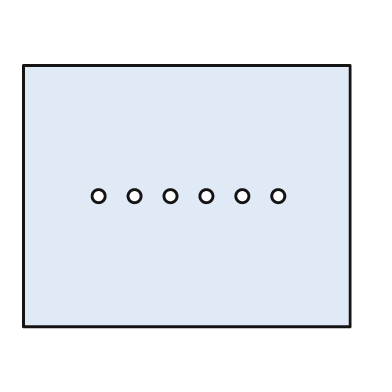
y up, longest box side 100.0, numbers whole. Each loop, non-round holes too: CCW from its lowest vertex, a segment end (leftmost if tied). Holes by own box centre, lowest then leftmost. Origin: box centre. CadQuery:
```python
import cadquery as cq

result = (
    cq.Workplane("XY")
    .moveTo(-50.0, -40.0)
    .lineTo(50.0, -40.0)
    .lineTo(50.0, 40.0)
    .lineTo(-50.0, 40.0)
    .close()
    .moveTo(-27.0, 0.0)
    .circle(2.0)
    .moveTo(-16.0, 0.0)
    .circle(2.0)
    .moveTo(-5.0, 0.0)
    .circle(2.0)
    .moveTo(6.0, 0.0)
    .circle(2.0)
    .moveTo(17.0, 0.0)
    .circle(2.0)
    .moveTo(28.0, 0.0)
    .circle(2.0)
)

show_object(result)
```